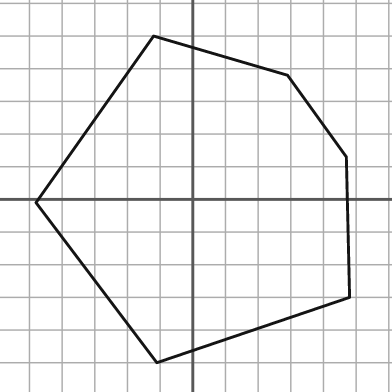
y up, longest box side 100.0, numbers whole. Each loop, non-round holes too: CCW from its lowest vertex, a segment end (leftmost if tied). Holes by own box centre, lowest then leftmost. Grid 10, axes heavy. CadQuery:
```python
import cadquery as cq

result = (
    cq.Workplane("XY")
    .moveTo(-11.0, -50.0)
    .lineTo(48.0, -30.0)
    .lineTo(47.0, 13.0)
    .lineTo(29.0, 38.0)
    .lineTo(-12.0, 50.0)
    .lineTo(-48.0, -1.0)
    .close()
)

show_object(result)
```